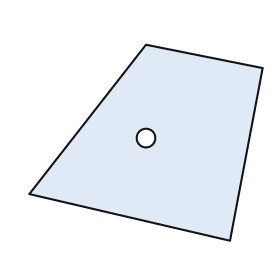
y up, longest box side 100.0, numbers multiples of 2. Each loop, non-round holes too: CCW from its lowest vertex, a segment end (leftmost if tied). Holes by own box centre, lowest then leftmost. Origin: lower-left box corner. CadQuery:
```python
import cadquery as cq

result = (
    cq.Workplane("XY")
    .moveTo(86.0, 0.0)
    .lineTo(100.0, 74.0)
    .lineTo(50.0, 84.0)
    .lineTo(0.0, 20.0)
    .close()
    .moveTo(50.0, 44.0)
    .circle(4.0)
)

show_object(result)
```